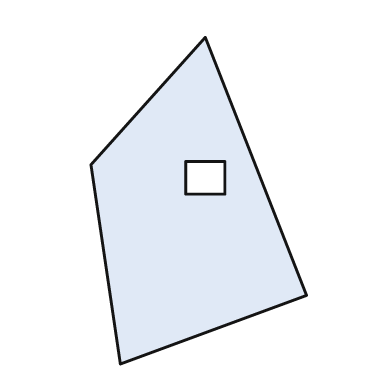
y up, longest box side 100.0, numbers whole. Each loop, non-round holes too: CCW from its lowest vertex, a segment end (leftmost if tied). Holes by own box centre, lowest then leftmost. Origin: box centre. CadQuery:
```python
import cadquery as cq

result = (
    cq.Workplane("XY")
    .moveTo(-24.0, -50.0)
    .lineTo(33.0, -29.0)
    .lineTo(2.0, 50.0)
    .lineTo(-33.0, 11.0)
    .close()
    .moveTo(-4.0, 2.0)
    .lineTo(8.0, 2.0)
    .lineTo(8.0, 12.0)
    .lineTo(-4.0, 12.0)
    .close()
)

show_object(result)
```